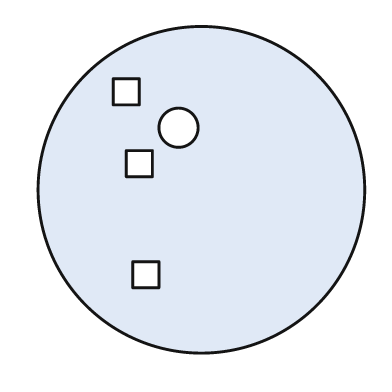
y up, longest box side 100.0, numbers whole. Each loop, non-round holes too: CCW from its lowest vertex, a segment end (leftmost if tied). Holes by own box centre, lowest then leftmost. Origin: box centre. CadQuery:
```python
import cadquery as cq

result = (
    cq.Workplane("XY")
    .moveTo(0.0, 0.0)
    .circle(50.0)
    .moveTo(-21.0, -30.0)
    .lineTo(-13.0, -30.0)
    .lineTo(-13.0, -22.0)
    .lineTo(-21.0, -22.0)
    .close()
    .moveTo(-23.0, 4.0)
    .lineTo(-15.0, 4.0)
    .lineTo(-15.0, 12.0)
    .lineTo(-23.0, 12.0)
    .close()
    .moveTo(-7.0, 19.0)
    .circle(6.0)
    .moveTo(-27.0, 26.0)
    .lineTo(-19.0, 26.0)
    .lineTo(-19.0, 34.0)
    .lineTo(-27.0, 34.0)
    .close()
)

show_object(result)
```